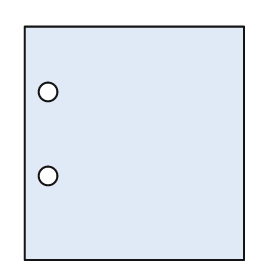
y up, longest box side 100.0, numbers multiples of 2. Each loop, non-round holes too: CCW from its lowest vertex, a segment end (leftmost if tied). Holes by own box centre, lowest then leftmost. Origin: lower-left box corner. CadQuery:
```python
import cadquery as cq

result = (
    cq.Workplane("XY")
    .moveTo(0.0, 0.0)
    .lineTo(94.0, 0.0)
    .lineTo(94.0, 100.0)
    .lineTo(0.0, 100.0)
    .close()
    .moveTo(10.0, 36.0)
    .circle(4.0)
    .moveTo(10.0, 72.0)
    .circle(4.0)
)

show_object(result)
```